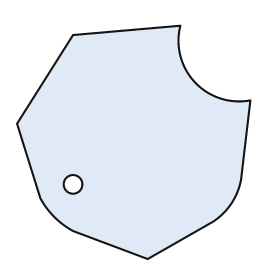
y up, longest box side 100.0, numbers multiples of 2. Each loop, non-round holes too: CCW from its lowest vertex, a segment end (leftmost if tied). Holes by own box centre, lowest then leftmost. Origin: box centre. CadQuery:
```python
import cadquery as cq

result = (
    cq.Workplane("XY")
    .moveTo(6.0, -50.0)
    .lineTo(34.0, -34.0)
    .threePointArc((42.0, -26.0), (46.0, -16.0))
    .lineTo(50.0, 18.0)
    .threePointArc((26.0, 26.0), (20.0, 50.0))
    .lineTo(-26.0, 46.0)
    .lineTo(-50.0, 8.0)
    .lineTo(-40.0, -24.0)
    .threePointArc((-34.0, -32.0), (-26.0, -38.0))
    .close()
    .moveTo(-26.0, -18.0)
    .circle(4.0)
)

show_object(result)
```